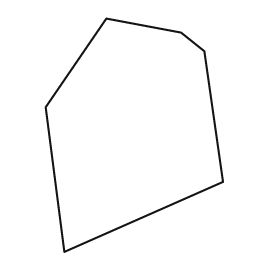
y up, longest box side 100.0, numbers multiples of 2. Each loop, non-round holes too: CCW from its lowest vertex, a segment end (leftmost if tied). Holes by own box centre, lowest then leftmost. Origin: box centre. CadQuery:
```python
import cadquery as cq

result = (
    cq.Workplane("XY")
    .moveTo(-30.0, -50.0)
    .lineTo(38.0, -20.0)
    .lineTo(30.0, 36.0)
    .lineTo(20.0, 44.0)
    .lineTo(-12.0, 50.0)
    .lineTo(-38.0, 12.0)
    .close()
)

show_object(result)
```